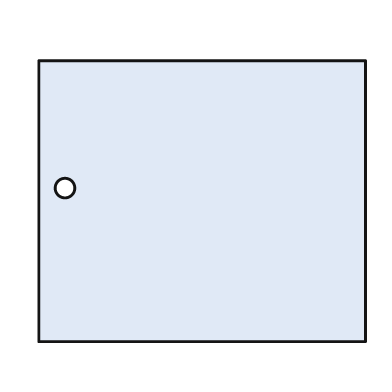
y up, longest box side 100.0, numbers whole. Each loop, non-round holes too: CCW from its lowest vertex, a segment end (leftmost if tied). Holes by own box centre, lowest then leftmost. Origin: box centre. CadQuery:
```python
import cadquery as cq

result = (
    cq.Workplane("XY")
    .moveTo(-50.0, -43.0)
    .lineTo(50.0, -43.0)
    .lineTo(50.0, 43.0)
    .lineTo(-50.0, 43.0)
    .close()
    .moveTo(-42.0, 4.0)
    .circle(3.0)
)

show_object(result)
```